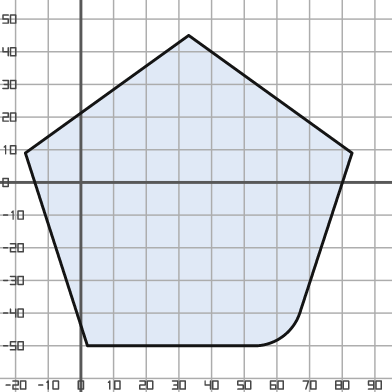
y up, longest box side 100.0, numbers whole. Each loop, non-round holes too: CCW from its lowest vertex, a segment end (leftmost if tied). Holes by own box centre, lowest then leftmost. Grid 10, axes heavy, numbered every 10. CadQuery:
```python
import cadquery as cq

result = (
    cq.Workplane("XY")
    .moveTo(2.0, -50.0)
    .lineTo(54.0, -50.0)
    .threePointArc((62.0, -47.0), (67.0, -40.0))
    .lineTo(83.0, 9.0)
    .lineTo(33.0, 45.0)
    .lineTo(-17.0, 9.0)
    .close()
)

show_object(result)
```